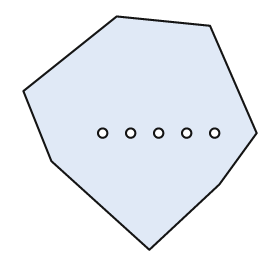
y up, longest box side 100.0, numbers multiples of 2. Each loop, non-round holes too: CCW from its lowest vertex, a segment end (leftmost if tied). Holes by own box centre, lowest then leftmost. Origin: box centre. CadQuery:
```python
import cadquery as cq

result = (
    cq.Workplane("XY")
    .moveTo(4.0, -50.0)
    .lineTo(34.0, -22.0)
    .lineTo(50.0, 0.0)
    .lineTo(30.0, 46.0)
    .lineTo(-10.0, 50.0)
    .lineTo(-50.0, 18.0)
    .lineTo(-38.0, -12.0)
    .close()
    .moveTo(-16.0, 0.0)
    .circle(2.0)
    .moveTo(-4.0, 0.0)
    .circle(2.0)
    .moveTo(8.0, 0.0)
    .circle(2.0)
    .moveTo(20.0, 0.0)
    .circle(2.0)
    .moveTo(32.0, 0.0)
    .circle(2.0)
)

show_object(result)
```